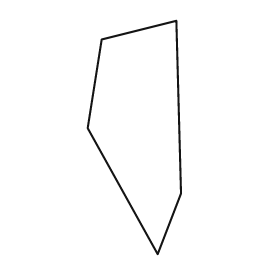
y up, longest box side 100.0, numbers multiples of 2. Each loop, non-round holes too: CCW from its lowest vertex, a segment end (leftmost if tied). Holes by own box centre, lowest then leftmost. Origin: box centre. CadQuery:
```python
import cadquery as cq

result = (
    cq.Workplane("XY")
    .moveTo(10.0, -50.0)
    .lineTo(20.0, -24.0)
    .lineTo(18.0, 50.0)
    .lineTo(-14.0, 42.0)
    .lineTo(-20.0, 4.0)
    .close()
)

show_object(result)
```